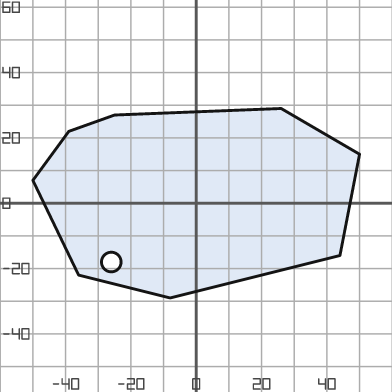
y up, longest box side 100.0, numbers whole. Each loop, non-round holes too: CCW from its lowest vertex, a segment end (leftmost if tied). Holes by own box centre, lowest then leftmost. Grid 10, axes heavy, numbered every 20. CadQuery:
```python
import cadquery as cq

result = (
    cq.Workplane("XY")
    .moveTo(-8.0, -29.0)
    .lineTo(44.0, -16.0)
    .lineTo(50.0, 15.0)
    .lineTo(26.0, 29.0)
    .lineTo(-25.0, 27.0)
    .lineTo(-39.0, 22.0)
    .lineTo(-50.0, 7.0)
    .lineTo(-36.0, -22.0)
    .close()
    .moveTo(-26.0, -18.0)
    .circle(3.0)
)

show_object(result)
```